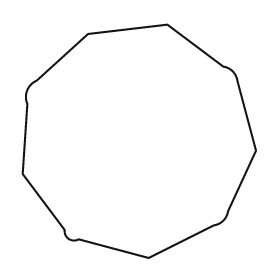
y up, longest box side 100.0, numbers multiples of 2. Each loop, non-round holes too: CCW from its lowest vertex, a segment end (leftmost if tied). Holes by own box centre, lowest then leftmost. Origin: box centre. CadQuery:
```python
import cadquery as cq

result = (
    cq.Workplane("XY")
    .moveTo(4.0, -50.0)
    .lineTo(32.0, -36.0)
    .threePointArc((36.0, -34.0), (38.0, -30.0))
    .lineTo(50.0, -4.0)
    .lineTo(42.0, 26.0)
    .threePointArc((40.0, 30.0), (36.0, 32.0))
    .lineTo(12.0, 50.0)
    .lineTo(-22.0, 46.0)
    .lineTo(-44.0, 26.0)
    .threePointArc((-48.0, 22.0), (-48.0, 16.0))
    .lineTo(-50.0, -14.0)
    .lineTo(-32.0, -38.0)
    .threePointArc((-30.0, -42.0), (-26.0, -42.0))
    .close()
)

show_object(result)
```